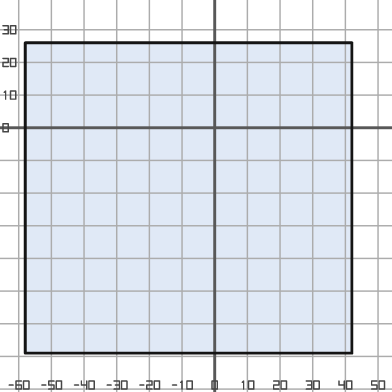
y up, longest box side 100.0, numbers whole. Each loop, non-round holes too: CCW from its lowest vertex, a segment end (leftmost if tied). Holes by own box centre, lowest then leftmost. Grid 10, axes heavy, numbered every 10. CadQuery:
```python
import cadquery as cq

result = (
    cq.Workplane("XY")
    .moveTo(-58.0, -69.0)
    .lineTo(42.0, -69.0)
    .lineTo(42.0, 26.0)
    .lineTo(-58.0, 26.0)
    .close()
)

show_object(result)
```